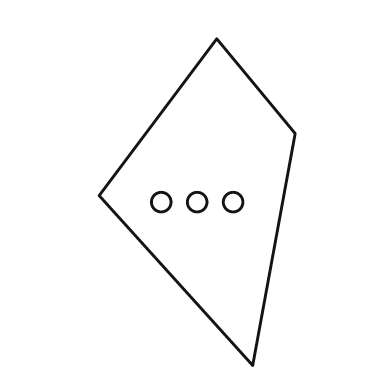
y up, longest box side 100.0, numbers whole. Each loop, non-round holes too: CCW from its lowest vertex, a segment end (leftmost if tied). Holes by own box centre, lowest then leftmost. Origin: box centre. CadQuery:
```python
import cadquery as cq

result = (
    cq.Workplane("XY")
    .moveTo(17.0, -50.0)
    .lineTo(30.0, 21.0)
    .lineTo(6.0, 50.0)
    .lineTo(-30.0, 2.0)
    .close()
    .moveTo(-11.0, 0.0)
    .circle(3.0)
    .moveTo(0.0, 0.0)
    .circle(3.0)
    .moveTo(11.0, 0.0)
    .circle(3.0)
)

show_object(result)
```